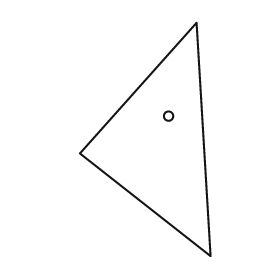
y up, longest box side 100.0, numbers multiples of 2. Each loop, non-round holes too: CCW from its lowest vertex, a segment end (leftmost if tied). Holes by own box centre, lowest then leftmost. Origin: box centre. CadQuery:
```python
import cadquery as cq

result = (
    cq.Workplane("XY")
    .moveTo(28.0, -50.0)
    .lineTo(22.0, 50.0)
    .lineTo(-28.0, -6.0)
    .close()
    .moveTo(10.0, 10.0)
    .circle(2.0)
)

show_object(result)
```